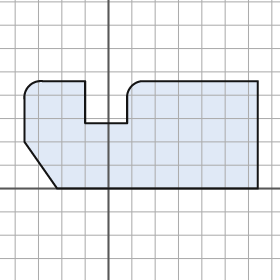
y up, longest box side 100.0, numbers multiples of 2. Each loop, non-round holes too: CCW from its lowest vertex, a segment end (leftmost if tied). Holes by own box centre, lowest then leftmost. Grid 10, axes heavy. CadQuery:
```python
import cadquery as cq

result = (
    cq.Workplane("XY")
    .moveTo(-22.0, 0.0)
    .lineTo(64.0, 0.0)
    .lineTo(64.0, 46.0)
    .lineTo(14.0, 46.0)
    .threePointArc((10.0, 44.0), (8.0, 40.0))
    .lineTo(8.0, 28.0)
    .lineTo(-10.0, 28.0)
    .lineTo(-10.0, 46.0)
    .lineTo(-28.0, 46.0)
    .threePointArc((-34.0, 44.0), (-36.0, 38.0))
    .lineTo(-36.0, 20.0)
    .close()
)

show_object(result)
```